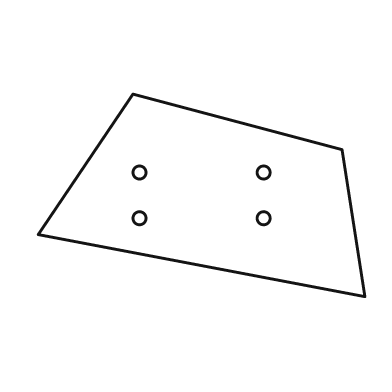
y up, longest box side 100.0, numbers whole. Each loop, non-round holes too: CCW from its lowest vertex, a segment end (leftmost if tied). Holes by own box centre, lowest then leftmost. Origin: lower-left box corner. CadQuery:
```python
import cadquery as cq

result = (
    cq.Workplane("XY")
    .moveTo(100.0, 0.0)
    .lineTo(93.0, 45.0)
    .lineTo(29.0, 62.0)
    .lineTo(0.0, 19.0)
    .close()
    .moveTo(31.0, 24.0)
    .circle(2.0)
    .moveTo(69.0, 24.0)
    .circle(2.0)
    .moveTo(31.0, 38.0)
    .circle(2.0)
    .moveTo(69.0, 38.0)
    .circle(2.0)
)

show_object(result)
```